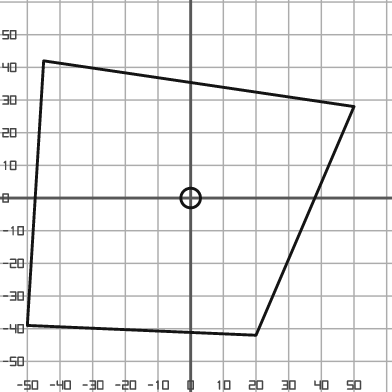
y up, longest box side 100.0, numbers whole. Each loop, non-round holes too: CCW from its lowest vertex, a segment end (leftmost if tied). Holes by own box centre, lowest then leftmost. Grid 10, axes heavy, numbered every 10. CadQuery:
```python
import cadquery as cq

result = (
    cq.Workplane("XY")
    .moveTo(20.0, -42.0)
    .lineTo(50.0, 28.0)
    .lineTo(-45.0, 42.0)
    .lineTo(-50.0, -39.0)
    .close()
    .moveTo(0.0, 0.0)
    .circle(3.0)
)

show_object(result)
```